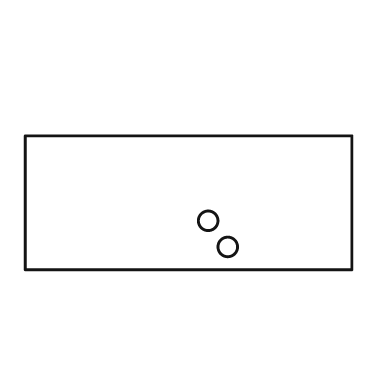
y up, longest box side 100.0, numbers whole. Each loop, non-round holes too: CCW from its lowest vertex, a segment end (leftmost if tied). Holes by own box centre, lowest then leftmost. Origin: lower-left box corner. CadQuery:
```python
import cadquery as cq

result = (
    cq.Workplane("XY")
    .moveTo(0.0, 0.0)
    .lineTo(100.0, 0.0)
    .lineTo(100.0, 41.0)
    .lineTo(0.0, 41.0)
    .close()
    .moveTo(62.0, 7.0)
    .circle(3.0)
    .moveTo(56.0, 15.0)
    .circle(3.0)
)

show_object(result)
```